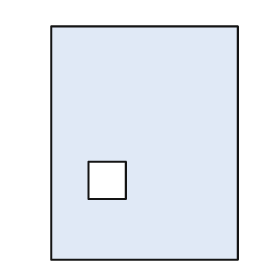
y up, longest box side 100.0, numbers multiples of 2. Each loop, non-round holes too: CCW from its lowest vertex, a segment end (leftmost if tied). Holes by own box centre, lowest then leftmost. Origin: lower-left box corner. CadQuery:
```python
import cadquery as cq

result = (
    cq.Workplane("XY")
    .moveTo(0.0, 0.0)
    .lineTo(80.0, 0.0)
    .lineTo(80.0, 100.0)
    .lineTo(0.0, 100.0)
    .close()
    .moveTo(16.0, 26.0)
    .lineTo(32.0, 26.0)
    .lineTo(32.0, 42.0)
    .lineTo(16.0, 42.0)
    .close()
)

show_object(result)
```